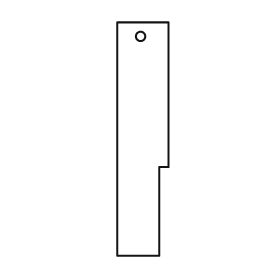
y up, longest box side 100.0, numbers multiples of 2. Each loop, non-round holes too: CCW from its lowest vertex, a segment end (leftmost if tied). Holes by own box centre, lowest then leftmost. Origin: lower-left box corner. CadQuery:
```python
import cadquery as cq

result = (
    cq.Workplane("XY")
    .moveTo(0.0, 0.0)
    .lineTo(18.0, 0.0)
    .lineTo(18.0, 38.0)
    .lineTo(22.0, 38.0)
    .lineTo(22.0, 100.0)
    .lineTo(0.0, 100.0)
    .close()
    .moveTo(10.0, 94.0)
    .circle(2.0)
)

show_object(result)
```